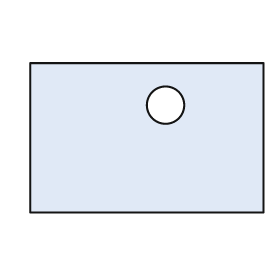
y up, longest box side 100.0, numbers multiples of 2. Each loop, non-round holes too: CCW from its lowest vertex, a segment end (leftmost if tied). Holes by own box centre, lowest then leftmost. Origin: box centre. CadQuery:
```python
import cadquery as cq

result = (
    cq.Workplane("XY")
    .moveTo(-50.0, -32.0)
    .lineTo(50.0, -32.0)
    .lineTo(50.0, 32.0)
    .lineTo(-50.0, 32.0)
    .close()
    .moveTo(8.0, 14.0)
    .circle(8.0)
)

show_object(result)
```